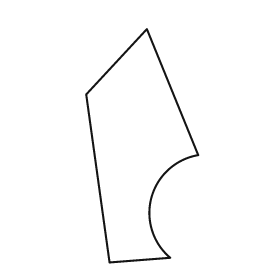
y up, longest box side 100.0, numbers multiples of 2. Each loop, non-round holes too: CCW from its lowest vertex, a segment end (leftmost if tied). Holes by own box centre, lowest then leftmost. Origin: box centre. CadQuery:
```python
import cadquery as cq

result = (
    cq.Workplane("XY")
    .moveTo(-14.0, -50.0)
    .lineTo(12.0, -48.0)
    .threePointArc((4.0, -22.0), (24.0, -4.0))
    .lineTo(2.0, 50.0)
    .lineTo(-24.0, 22.0)
    .close()
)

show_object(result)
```